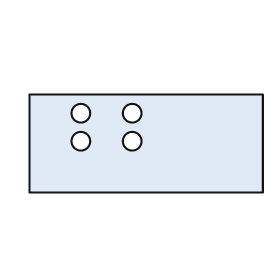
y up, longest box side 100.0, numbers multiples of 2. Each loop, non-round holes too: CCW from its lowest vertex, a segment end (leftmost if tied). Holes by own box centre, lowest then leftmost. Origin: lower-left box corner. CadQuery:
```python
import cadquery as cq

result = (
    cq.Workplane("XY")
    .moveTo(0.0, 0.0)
    .lineTo(100.0, 0.0)
    .lineTo(100.0, 42.0)
    .lineTo(0.0, 42.0)
    .close()
    .moveTo(22.0, 22.0)
    .circle(4.0)
    .moveTo(44.0, 22.0)
    .circle(4.0)
    .moveTo(22.0, 34.0)
    .circle(4.0)
    .moveTo(44.0, 34.0)
    .circle(4.0)
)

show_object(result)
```